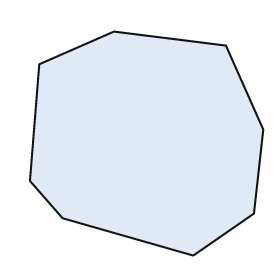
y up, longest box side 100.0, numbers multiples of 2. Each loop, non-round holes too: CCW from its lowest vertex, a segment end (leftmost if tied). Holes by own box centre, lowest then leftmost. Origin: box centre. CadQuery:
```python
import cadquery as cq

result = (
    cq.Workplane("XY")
    .moveTo(20.0, -48.0)
    .lineTo(46.0, -30.0)
    .lineTo(50.0, 6.0)
    .lineTo(34.0, 42.0)
    .lineTo(-14.0, 48.0)
    .lineTo(-46.0, 34.0)
    .lineTo(-50.0, -16.0)
    .lineTo(-36.0, -32.0)
    .close()
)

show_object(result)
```